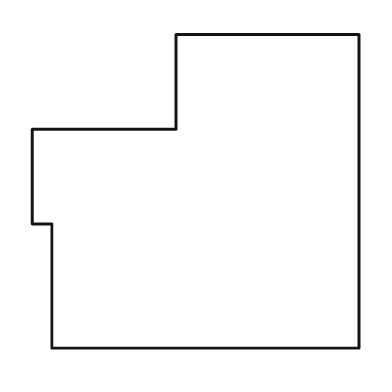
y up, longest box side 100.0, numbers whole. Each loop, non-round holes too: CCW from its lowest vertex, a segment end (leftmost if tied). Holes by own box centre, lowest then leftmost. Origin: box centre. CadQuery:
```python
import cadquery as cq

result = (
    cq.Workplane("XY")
    .moveTo(-44.0, -48.0)
    .lineTo(50.0, -48.0)
    .lineTo(50.0, 48.0)
    .lineTo(-6.0, 48.0)
    .lineTo(-6.0, 19.0)
    .lineTo(-50.0, 19.0)
    .lineTo(-50.0, -10.0)
    .lineTo(-44.0, -10.0)
    .close()
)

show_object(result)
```